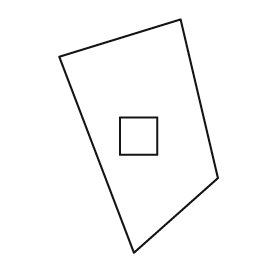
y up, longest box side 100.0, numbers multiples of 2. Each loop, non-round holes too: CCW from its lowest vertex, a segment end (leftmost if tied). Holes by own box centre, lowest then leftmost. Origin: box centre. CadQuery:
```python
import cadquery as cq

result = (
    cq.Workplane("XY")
    .moveTo(-2.0, -50.0)
    .lineTo(34.0, -18.0)
    .lineTo(18.0, 50.0)
    .lineTo(-34.0, 34.0)
    .close()
    .moveTo(-8.0, -8.0)
    .lineTo(8.0, -8.0)
    .lineTo(8.0, 8.0)
    .lineTo(-8.0, 8.0)
    .close()
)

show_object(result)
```